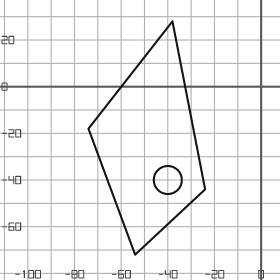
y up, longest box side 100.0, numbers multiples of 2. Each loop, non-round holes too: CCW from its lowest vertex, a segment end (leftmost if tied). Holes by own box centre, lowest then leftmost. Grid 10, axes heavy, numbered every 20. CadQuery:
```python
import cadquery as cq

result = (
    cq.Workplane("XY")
    .moveTo(-54.0, -72.0)
    .lineTo(-24.0, -44.0)
    .lineTo(-38.0, 28.0)
    .lineTo(-74.0, -18.0)
    .close()
    .moveTo(-40.0, -40.0)
    .circle(6.0)
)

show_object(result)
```